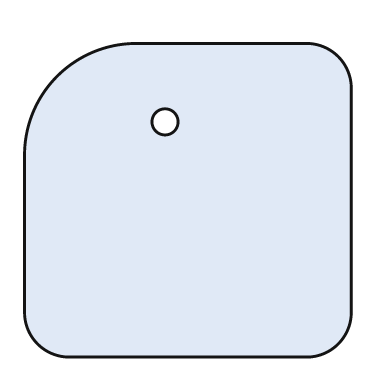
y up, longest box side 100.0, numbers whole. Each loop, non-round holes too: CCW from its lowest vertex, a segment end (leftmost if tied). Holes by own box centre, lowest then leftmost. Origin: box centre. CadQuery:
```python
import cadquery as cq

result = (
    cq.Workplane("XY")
    .moveTo(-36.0, -48.0)
    .lineTo(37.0, -48.0)
    .threePointArc((46.0, -44.0), (50.0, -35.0))
    .lineTo(50.0, 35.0)
    .threePointArc((46.0, 44.0), (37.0, 48.0))
    .lineTo(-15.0, 48.0)
    .threePointArc((-40.0, 38.0), (-50.0, 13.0))
    .lineTo(-50.0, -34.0)
    .threePointArc((-46.0, -44.0), (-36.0, -48.0))
    .close()
    .moveTo(-7.0, 24.0)
    .circle(4.0)
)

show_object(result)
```